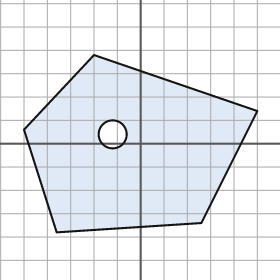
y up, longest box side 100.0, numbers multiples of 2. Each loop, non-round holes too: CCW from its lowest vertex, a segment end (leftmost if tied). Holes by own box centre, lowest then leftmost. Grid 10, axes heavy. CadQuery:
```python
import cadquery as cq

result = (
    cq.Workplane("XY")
    .moveTo(-36.0, -38.0)
    .lineTo(26.0, -34.0)
    .lineTo(50.0, 14.0)
    .lineTo(-20.0, 38.0)
    .lineTo(-50.0, 6.0)
    .close()
    .moveTo(-12.0, 4.0)
    .circle(6.0)
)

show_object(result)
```